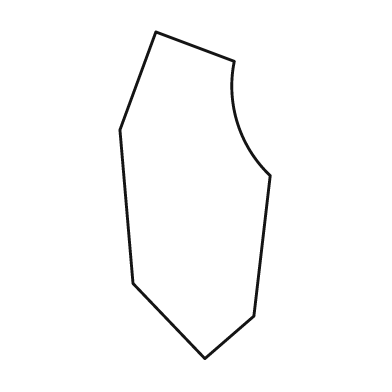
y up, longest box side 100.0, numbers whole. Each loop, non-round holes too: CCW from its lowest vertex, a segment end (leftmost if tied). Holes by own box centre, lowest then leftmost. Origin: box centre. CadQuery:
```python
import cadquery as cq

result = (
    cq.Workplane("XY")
    .moveTo(3.0, -50.0)
    .lineTo(18.0, -37.0)
    .lineTo(23.0, 6.0)
    .threePointArc((13.0, 22.0), (12.0, 41.0))
    .lineTo(-12.0, 50.0)
    .lineTo(-23.0, 20.0)
    .lineTo(-19.0, -27.0)
    .close()
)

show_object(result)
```